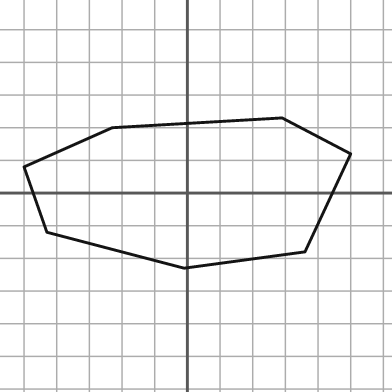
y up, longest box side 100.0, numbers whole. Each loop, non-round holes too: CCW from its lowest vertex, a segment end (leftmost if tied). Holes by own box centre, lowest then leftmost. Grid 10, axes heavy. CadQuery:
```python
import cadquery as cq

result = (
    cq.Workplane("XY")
    .moveTo(-1.0, -23.0)
    .lineTo(36.0, -18.0)
    .lineTo(50.0, 12.0)
    .lineTo(29.0, 23.0)
    .lineTo(-23.0, 20.0)
    .lineTo(-50.0, 8.0)
    .lineTo(-43.0, -12.0)
    .close()
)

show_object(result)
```